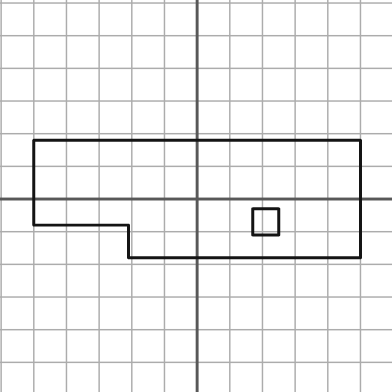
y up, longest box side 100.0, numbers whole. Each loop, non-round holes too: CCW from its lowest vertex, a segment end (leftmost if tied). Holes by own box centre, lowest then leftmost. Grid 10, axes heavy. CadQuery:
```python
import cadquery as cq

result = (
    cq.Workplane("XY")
    .moveTo(-21.0, -18.0)
    .lineTo(50.0, -18.0)
    .lineTo(50.0, 18.0)
    .lineTo(-50.0, 18.0)
    .lineTo(-50.0, -8.0)
    .lineTo(-21.0, -8.0)
    .close()
    .moveTo(17.0, -11.0)
    .lineTo(25.0, -11.0)
    .lineTo(25.0, -3.0)
    .lineTo(17.0, -3.0)
    .close()
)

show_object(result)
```